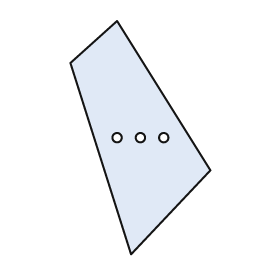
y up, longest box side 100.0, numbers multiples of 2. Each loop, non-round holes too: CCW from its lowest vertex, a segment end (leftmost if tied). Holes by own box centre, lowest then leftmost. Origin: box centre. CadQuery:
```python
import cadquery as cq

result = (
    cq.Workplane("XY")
    .moveTo(-4.0, -50.0)
    .lineTo(30.0, -14.0)
    .lineTo(-10.0, 50.0)
    .lineTo(-30.0, 32.0)
    .close()
    .moveTo(-10.0, 0.0)
    .circle(2.0)
    .moveTo(0.0, 0.0)
    .circle(2.0)
    .moveTo(10.0, 0.0)
    .circle(2.0)
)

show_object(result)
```